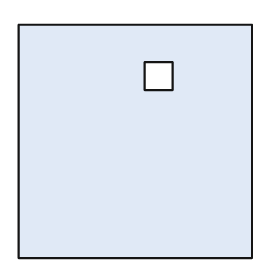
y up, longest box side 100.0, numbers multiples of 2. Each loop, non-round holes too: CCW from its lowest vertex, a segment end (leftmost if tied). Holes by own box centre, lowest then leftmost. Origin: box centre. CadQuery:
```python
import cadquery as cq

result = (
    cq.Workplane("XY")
    .moveTo(-50.0, -50.0)
    .lineTo(50.0, -50.0)
    .lineTo(50.0, 50.0)
    .lineTo(-50.0, 50.0)
    .close()
    .moveTo(4.0, 22.0)
    .lineTo(16.0, 22.0)
    .lineTo(16.0, 34.0)
    .lineTo(4.0, 34.0)
    .close()
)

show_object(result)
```